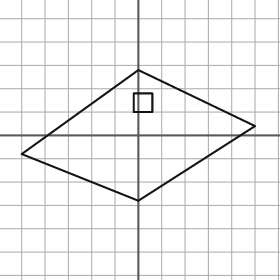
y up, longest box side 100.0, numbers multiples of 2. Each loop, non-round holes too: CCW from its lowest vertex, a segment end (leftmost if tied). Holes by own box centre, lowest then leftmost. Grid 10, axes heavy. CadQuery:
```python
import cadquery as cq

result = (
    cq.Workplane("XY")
    .moveTo(0.0, -28.0)
    .lineTo(50.0, 4.0)
    .lineTo(0.0, 28.0)
    .lineTo(-50.0, -8.0)
    .close()
    .moveTo(-2.0, 10.0)
    .lineTo(6.0, 10.0)
    .lineTo(6.0, 18.0)
    .lineTo(-2.0, 18.0)
    .close()
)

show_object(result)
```